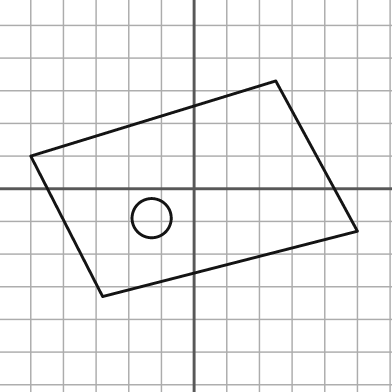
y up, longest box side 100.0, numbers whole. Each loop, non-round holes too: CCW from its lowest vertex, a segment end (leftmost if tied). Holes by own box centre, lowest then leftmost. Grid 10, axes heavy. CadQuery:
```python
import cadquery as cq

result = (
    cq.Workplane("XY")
    .moveTo(-28.0, -33.0)
    .lineTo(50.0, -13.0)
    .lineTo(25.0, 33.0)
    .lineTo(-50.0, 10.0)
    .close()
    .moveTo(-13.0, -9.0)
    .circle(6.0)
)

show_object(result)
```